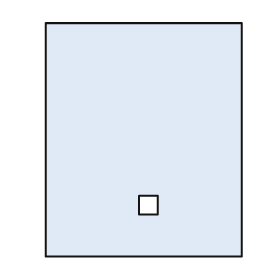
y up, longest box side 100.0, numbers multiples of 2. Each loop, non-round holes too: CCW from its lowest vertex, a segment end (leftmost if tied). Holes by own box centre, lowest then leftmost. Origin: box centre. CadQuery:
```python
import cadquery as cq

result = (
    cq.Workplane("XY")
    .moveTo(-42.0, -50.0)
    .lineTo(42.0, -50.0)
    .lineTo(42.0, 50.0)
    .lineTo(-42.0, 50.0)
    .close()
    .moveTo(-2.0, -32.0)
    .lineTo(6.0, -32.0)
    .lineTo(6.0, -24.0)
    .lineTo(-2.0, -24.0)
    .close()
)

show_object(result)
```